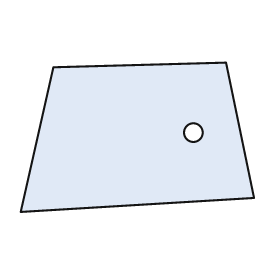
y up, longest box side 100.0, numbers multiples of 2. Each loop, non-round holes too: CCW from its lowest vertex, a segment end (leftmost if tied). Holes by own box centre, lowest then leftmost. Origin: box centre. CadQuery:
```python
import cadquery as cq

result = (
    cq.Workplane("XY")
    .moveTo(-50.0, -32.0)
    .lineTo(50.0, -26.0)
    .lineTo(38.0, 32.0)
    .lineTo(-36.0, 30.0)
    .close()
    .moveTo(24.0, 2.0)
    .circle(4.0)
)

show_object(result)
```